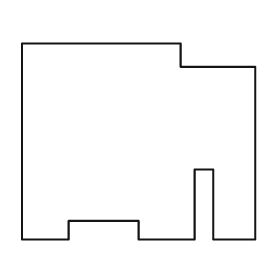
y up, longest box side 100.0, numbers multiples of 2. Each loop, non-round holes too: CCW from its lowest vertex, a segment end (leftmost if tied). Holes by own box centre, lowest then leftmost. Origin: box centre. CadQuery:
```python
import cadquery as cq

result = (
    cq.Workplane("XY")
    .moveTo(-50.0, -42.0)
    .lineTo(-30.0, -42.0)
    .lineTo(-30.0, -34.0)
    .lineTo(0.0, -34.0)
    .lineTo(0.0, -42.0)
    .lineTo(24.0, -42.0)
    .lineTo(24.0, -12.0)
    .lineTo(32.0, -12.0)
    .lineTo(32.0, -42.0)
    .lineTo(50.0, -42.0)
    .lineTo(50.0, 32.0)
    .lineTo(18.0, 32.0)
    .lineTo(18.0, 42.0)
    .lineTo(-50.0, 42.0)
    .close()
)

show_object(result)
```